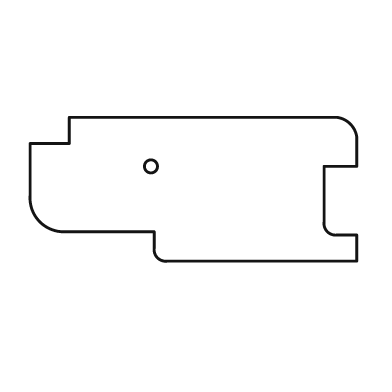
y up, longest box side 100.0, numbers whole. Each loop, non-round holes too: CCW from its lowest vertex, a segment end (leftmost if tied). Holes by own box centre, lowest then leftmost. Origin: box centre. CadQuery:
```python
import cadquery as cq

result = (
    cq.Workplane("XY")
    .moveTo(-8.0, -22.0)
    .lineTo(50.0, -22.0)
    .lineTo(50.0, -14.0)
    .lineTo(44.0, -14.0)
    .threePointArc((41.0, -13.0), (40.0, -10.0))
    .lineTo(40.0, 7.0)
    .lineTo(50.0, 7.0)
    .lineTo(50.0, 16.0)
    .threePointArc((48.0, 20.0), (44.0, 22.0))
    .lineTo(-38.0, 22.0)
    .lineTo(-38.0, 14.0)
    .lineTo(-50.0, 14.0)
    .lineTo(-50.0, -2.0)
    .threePointArc((-47.0, -10.0), (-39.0, -13.0))
    .lineTo(-12.0, -13.0)
    .lineTo(-12.0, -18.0)
    .threePointArc((-11.0, -21.0), (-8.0, -22.0))
    .close()
    .moveTo(-13.0, 7.0)
    .circle(2.0)
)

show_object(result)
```